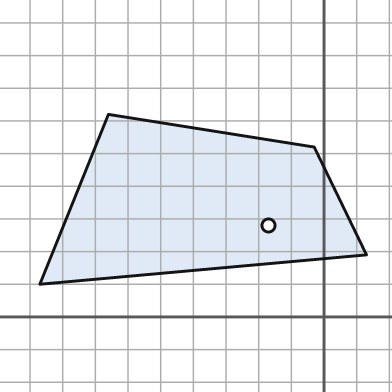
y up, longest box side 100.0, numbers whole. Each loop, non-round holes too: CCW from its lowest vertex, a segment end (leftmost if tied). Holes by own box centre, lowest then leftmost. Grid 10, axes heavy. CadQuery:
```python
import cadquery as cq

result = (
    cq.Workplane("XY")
    .moveTo(-87.0, 10.0)
    .lineTo(13.0, 19.0)
    .lineTo(-3.0, 52.0)
    .lineTo(-66.0, 62.0)
    .close()
    .moveTo(-17.0, 28.0)
    .circle(2.0)
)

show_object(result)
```